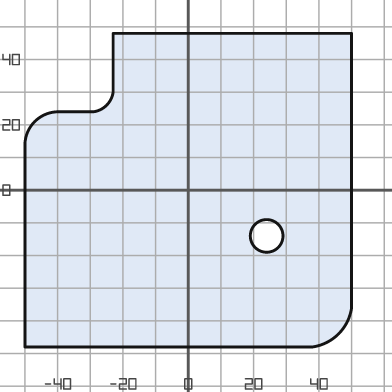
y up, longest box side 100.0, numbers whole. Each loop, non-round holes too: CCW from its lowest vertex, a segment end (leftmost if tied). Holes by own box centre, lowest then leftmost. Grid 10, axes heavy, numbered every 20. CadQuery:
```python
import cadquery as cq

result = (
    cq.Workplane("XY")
    .moveTo(-50.0, -48.0)
    .lineTo(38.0, -48.0)
    .threePointArc((46.0, -44.0), (50.0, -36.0))
    .lineTo(50.0, 48.0)
    .lineTo(-23.0, 48.0)
    .lineTo(-23.0, 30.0)
    .threePointArc((-25.0, 26.0), (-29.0, 24.0))
    .lineTo(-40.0, 24.0)
    .threePointArc((-47.0, 21.0), (-50.0, 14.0))
    .close()
    .moveTo(24.0, -14.0)
    .circle(5.0)
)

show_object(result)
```